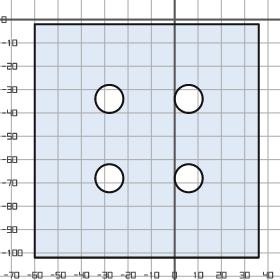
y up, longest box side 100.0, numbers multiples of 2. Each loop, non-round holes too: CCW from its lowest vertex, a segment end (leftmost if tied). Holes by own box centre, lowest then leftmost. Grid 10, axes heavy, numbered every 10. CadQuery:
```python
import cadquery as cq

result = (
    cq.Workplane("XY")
    .moveTo(-60.0, -102.0)
    .lineTo(36.0, -102.0)
    .lineTo(36.0, -2.0)
    .lineTo(-60.0, -2.0)
    .close()
    .moveTo(-28.0, -68.0)
    .circle(6.0)
    .moveTo(6.0, -68.0)
    .circle(6.0)
    .moveTo(-28.0, -34.0)
    .circle(6.0)
    .moveTo(6.0, -34.0)
    .circle(6.0)
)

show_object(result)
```